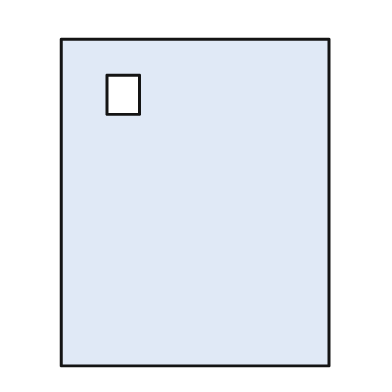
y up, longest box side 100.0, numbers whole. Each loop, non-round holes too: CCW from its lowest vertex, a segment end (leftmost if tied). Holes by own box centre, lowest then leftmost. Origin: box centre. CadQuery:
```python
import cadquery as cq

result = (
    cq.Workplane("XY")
    .moveTo(-41.0, -50.0)
    .lineTo(41.0, -50.0)
    .lineTo(41.0, 50.0)
    .lineTo(-41.0, 50.0)
    .close()
    .moveTo(-27.0, 27.0)
    .lineTo(-17.0, 27.0)
    .lineTo(-17.0, 39.0)
    .lineTo(-27.0, 39.0)
    .close()
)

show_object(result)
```